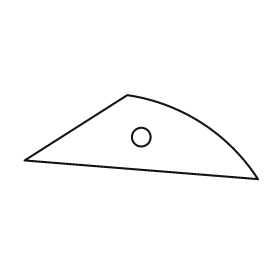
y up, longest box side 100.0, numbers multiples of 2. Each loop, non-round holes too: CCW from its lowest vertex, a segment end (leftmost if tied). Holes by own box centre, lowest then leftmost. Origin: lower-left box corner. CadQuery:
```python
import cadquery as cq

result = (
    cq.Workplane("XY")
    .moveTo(100.0, 0.0)
    .threePointArc((76.0, 24.0), (44.0, 36.0))
    .lineTo(0.0, 8.0)
    .close()
    .moveTo(50.0, 18.0)
    .circle(4.0)
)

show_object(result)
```